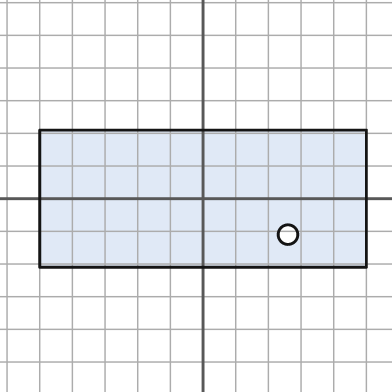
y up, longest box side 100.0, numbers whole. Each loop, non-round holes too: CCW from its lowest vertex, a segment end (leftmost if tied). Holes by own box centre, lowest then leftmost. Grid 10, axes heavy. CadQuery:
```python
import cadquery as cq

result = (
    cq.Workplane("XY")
    .moveTo(-50.0, -21.0)
    .lineTo(50.0, -21.0)
    .lineTo(50.0, 21.0)
    .lineTo(-50.0, 21.0)
    .close()
    .moveTo(26.0, -11.0)
    .circle(3.0)
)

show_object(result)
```